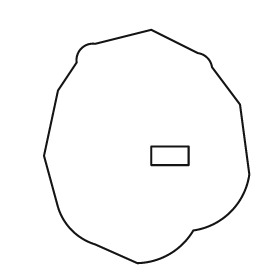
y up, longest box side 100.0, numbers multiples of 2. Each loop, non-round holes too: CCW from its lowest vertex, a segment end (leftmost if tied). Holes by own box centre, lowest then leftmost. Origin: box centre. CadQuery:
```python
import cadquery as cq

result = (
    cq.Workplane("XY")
    .moveTo(-4.0, -50.0)
    .threePointArc((10.0, -46.0), (20.0, -36.0))
    .threePointArc((36.0, -28.0), (44.0, -12.0))
    .lineTo(40.0, 18.0)
    .lineTo(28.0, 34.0)
    .threePointArc((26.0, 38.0), (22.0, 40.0))
    .lineTo(2.0, 50.0)
    .lineTo(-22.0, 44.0)
    .threePointArc((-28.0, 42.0), (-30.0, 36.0))
    .lineTo(-38.0, 24.0)
    .lineTo(-44.0, -4.0)
    .lineTo(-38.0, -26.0)
    .threePointArc((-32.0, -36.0), (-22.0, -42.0))
    .close()
    .moveTo(2.0, -8.0)
    .lineTo(18.0, -8.0)
    .lineTo(18.0, 0.0)
    .lineTo(2.0, 0.0)
    .close()
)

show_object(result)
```